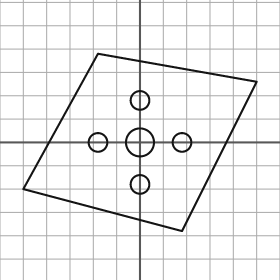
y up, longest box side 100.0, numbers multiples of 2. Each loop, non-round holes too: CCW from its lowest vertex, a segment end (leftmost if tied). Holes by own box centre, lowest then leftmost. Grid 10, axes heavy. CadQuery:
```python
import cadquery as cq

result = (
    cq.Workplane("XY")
    .moveTo(18.0, -38.0)
    .lineTo(50.0, 26.0)
    .lineTo(-18.0, 38.0)
    .lineTo(-50.0, -20.0)
    .close()
    .moveTo(0.0, -18.0)
    .circle(4.0)
    .moveTo(-18.0, 0.0)
    .circle(4.0)
    .moveTo(0.0, 0.0)
    .circle(6.0)
    .moveTo(18.0, 0.0)
    .circle(4.0)
    .moveTo(0.0, 18.0)
    .circle(4.0)
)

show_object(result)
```